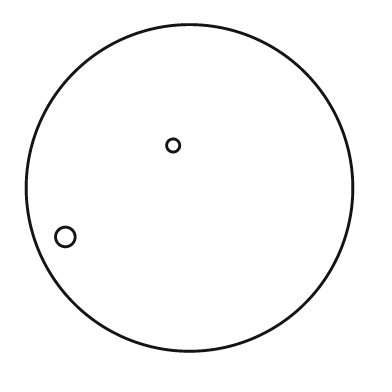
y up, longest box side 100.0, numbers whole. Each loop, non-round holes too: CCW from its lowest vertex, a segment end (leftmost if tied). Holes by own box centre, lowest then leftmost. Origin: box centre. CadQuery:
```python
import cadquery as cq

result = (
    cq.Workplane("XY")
    .moveTo(0.0, 0.0)
    .circle(50.0)
    .moveTo(-38.0, -15.0)
    .circle(3.0)
    .moveTo(-5.0, 13.0)
    .circle(2.0)
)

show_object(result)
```